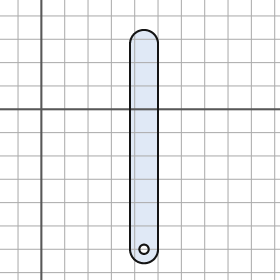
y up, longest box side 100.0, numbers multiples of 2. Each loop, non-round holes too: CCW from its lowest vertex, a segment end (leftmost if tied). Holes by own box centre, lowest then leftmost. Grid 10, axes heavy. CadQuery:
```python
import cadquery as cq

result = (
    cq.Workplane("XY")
    .moveTo(38.0, -60.0)
    .threePointArc((44.0, -66.0), (50.0, -60.0))
    .lineTo(50.0, 28.0)
    .threePointArc((44.0, 34.0), (38.0, 28.0))
    .close()
    .moveTo(44.0, -60.0)
    .circle(2.0)
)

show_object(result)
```